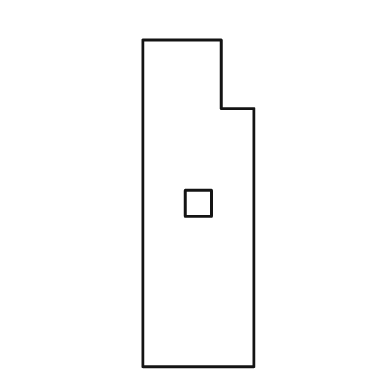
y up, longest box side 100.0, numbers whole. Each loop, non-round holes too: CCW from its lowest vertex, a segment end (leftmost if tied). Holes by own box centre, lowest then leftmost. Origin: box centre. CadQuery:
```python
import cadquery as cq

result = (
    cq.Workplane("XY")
    .moveTo(-17.0, -50.0)
    .lineTo(17.0, -50.0)
    .lineTo(17.0, 29.0)
    .lineTo(7.0, 29.0)
    .lineTo(7.0, 50.0)
    .lineTo(-17.0, 50.0)
    .close()
    .moveTo(-4.0, -4.0)
    .lineTo(4.0, -4.0)
    .lineTo(4.0, 4.0)
    .lineTo(-4.0, 4.0)
    .close()
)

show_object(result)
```